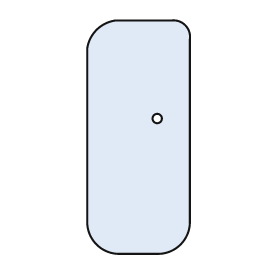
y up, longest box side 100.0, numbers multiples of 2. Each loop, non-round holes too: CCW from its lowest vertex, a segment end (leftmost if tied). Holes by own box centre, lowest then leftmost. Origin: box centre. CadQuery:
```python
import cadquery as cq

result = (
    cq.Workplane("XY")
    .moveTo(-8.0, -50.0)
    .lineTo(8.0, -50.0)
    .threePointArc((18.0, -46.0), (22.0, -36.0))
    .lineTo(22.0, 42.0)
    .threePointArc((20.0, 48.0), (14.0, 50.0))
    .lineTo(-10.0, 50.0)
    .threePointArc((-18.0, 46.0), (-22.0, 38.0))
    .lineTo(-22.0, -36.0)
    .threePointArc((-18.0, -46.0), (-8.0, -50.0))
    .close()
    .moveTo(8.0, 8.0)
    .circle(2.0)
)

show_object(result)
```